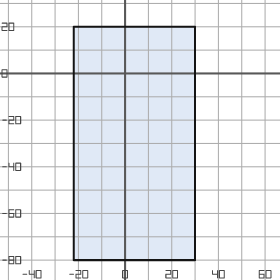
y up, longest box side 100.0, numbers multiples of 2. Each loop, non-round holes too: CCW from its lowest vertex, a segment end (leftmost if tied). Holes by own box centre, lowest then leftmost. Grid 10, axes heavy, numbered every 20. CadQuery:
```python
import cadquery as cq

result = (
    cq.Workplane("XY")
    .moveTo(-22.0, -80.0)
    .lineTo(30.0, -80.0)
    .lineTo(30.0, 20.0)
    .lineTo(-22.0, 20.0)
    .close()
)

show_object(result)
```